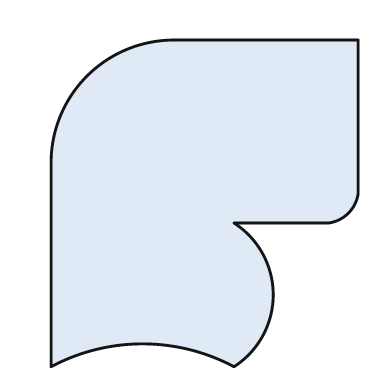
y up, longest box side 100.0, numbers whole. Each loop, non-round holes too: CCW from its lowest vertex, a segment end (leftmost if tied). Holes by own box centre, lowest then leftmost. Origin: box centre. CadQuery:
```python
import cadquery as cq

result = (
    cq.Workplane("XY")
    .moveTo(-47.0, -50.0)
    .threePointArc((-19.0, -43.0), (9.0, -50.0))
    .threePointArc((21.0, -28.0), (9.0, -6.0))
    .lineTo(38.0, -6.0)
    .threePointArc((44.0, -3.0), (47.0, 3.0))
    .lineTo(47.0, 50.0)
    .lineTo(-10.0, 50.0)
    .threePointArc((-36.0, 39.0), (-47.0, 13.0))
    .close()
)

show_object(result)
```